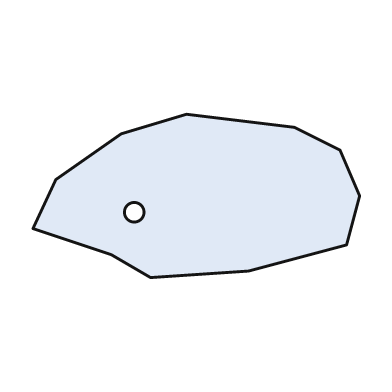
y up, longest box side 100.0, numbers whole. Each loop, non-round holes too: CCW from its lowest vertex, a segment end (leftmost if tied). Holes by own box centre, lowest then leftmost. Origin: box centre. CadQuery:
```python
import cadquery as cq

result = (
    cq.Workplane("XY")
    .moveTo(-14.0, -25.0)
    .lineTo(16.0, -23.0)
    .lineTo(46.0, -15.0)
    .lineTo(50.0, 0.0)
    .lineTo(44.0, 14.0)
    .lineTo(30.0, 21.0)
    .lineTo(-3.0, 25.0)
    .lineTo(-23.0, 19.0)
    .lineTo(-43.0, 5.0)
    .lineTo(-50.0, -10.0)
    .lineTo(-26.0, -18.0)
    .close()
    .moveTo(-19.0, -5.0)
    .circle(3.0)
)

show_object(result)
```